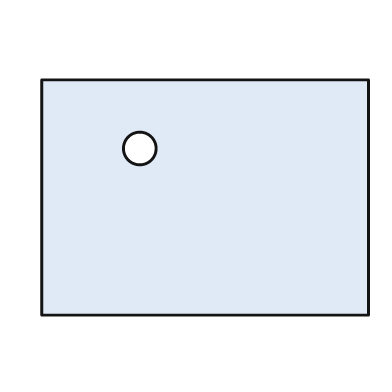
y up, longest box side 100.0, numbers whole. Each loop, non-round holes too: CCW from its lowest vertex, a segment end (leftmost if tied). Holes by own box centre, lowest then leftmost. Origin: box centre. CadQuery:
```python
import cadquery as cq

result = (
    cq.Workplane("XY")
    .moveTo(-50.0, -36.0)
    .lineTo(50.0, -36.0)
    .lineTo(50.0, 36.0)
    .lineTo(-50.0, 36.0)
    .close()
    .moveTo(-20.0, 15.0)
    .circle(5.0)
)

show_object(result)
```